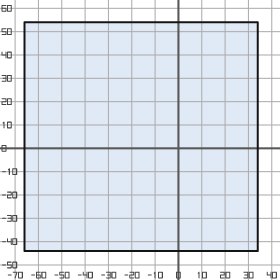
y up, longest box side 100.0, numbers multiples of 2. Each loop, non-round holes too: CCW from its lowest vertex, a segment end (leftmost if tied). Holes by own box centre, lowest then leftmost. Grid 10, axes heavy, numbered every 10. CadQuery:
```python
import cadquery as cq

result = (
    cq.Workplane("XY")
    .moveTo(-66.0, -44.0)
    .lineTo(34.0, -44.0)
    .lineTo(34.0, 54.0)
    .lineTo(-66.0, 54.0)
    .close()
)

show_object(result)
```